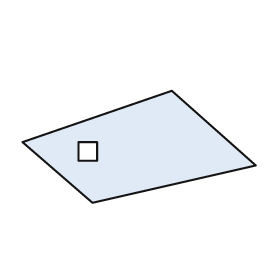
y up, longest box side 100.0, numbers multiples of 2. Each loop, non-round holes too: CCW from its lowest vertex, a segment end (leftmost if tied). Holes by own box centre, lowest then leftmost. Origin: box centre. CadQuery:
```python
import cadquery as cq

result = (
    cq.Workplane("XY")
    .moveTo(-20.0, -24.0)
    .lineTo(50.0, -8.0)
    .lineTo(14.0, 24.0)
    .lineTo(-50.0, 2.0)
    .close()
    .moveTo(-26.0, -6.0)
    .lineTo(-18.0, -6.0)
    .lineTo(-18.0, 2.0)
    .lineTo(-26.0, 2.0)
    .close()
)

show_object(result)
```